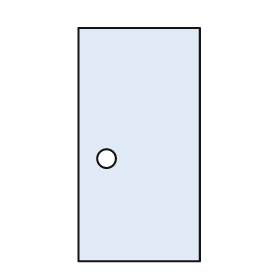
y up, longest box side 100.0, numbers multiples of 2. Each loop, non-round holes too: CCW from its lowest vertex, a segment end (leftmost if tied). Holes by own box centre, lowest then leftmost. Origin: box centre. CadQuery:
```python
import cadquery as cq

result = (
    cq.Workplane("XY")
    .moveTo(-26.0, -50.0)
    .lineTo(26.0, -50.0)
    .lineTo(26.0, 50.0)
    .lineTo(-26.0, 50.0)
    .close()
    .moveTo(-14.0, -6.0)
    .circle(4.0)
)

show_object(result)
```